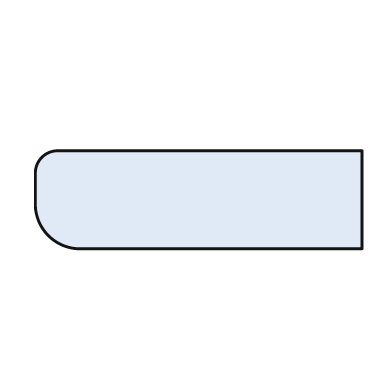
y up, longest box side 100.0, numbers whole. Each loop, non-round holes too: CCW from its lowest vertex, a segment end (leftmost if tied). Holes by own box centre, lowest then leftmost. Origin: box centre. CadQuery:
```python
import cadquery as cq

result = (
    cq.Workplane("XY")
    .moveTo(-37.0, -15.0)
    .lineTo(50.0, -15.0)
    .lineTo(50.0, 15.0)
    .lineTo(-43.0, 15.0)
    .threePointArc((-48.0, 13.0), (-50.0, 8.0))
    .lineTo(-50.0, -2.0)
    .threePointArc((-46.0, -11.0), (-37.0, -15.0))
    .close()
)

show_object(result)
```